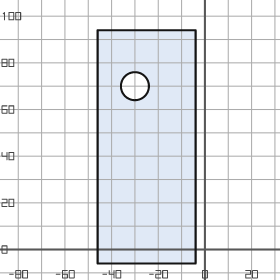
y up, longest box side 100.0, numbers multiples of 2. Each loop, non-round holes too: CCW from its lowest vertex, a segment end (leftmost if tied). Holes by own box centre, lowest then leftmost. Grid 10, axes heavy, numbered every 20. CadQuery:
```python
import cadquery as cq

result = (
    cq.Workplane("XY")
    .moveTo(-46.0, -6.0)
    .lineTo(-4.0, -6.0)
    .lineTo(-4.0, 94.0)
    .lineTo(-46.0, 94.0)
    .close()
    .moveTo(-30.0, 70.0)
    .circle(6.0)
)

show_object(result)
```